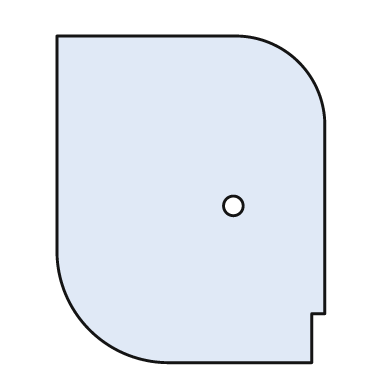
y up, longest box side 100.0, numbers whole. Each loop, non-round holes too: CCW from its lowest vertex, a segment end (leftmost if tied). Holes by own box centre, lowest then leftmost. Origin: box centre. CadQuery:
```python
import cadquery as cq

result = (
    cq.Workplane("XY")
    .moveTo(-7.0, -50.0)
    .lineTo(37.0, -50.0)
    .lineTo(37.0, -35.0)
    .lineTo(41.0, -35.0)
    .lineTo(41.0, 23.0)
    .threePointArc((33.0, 42.0), (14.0, 50.0))
    .lineTo(-41.0, 50.0)
    .lineTo(-41.0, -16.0)
    .threePointArc((-31.0, -40.0), (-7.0, -50.0))
    .close()
    .moveTo(13.0, -2.0)
    .circle(3.0)
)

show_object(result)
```